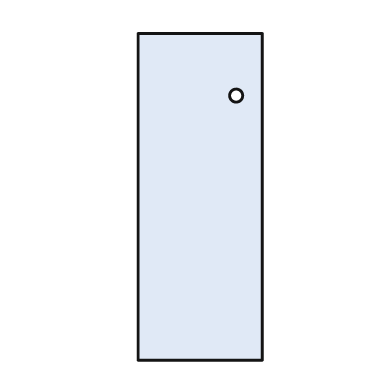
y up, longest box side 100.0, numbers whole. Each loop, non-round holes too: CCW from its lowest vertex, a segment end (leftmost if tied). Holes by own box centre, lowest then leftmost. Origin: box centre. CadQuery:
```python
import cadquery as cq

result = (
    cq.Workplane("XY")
    .moveTo(-19.0, -50.0)
    .lineTo(19.0, -50.0)
    .lineTo(19.0, 50.0)
    .lineTo(-19.0, 50.0)
    .close()
    .moveTo(11.0, 31.0)
    .circle(2.0)
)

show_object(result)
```